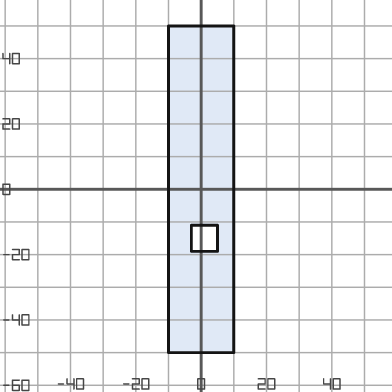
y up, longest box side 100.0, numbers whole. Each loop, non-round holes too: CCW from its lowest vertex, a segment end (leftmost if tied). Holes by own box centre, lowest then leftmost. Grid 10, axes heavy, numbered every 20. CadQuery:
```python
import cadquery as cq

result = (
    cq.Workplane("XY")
    .moveTo(-10.0, -50.0)
    .lineTo(10.0, -50.0)
    .lineTo(10.0, 50.0)
    .lineTo(-10.0, 50.0)
    .close()
    .moveTo(-3.0, -19.0)
    .lineTo(5.0, -19.0)
    .lineTo(5.0, -11.0)
    .lineTo(-3.0, -11.0)
    .close()
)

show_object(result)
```